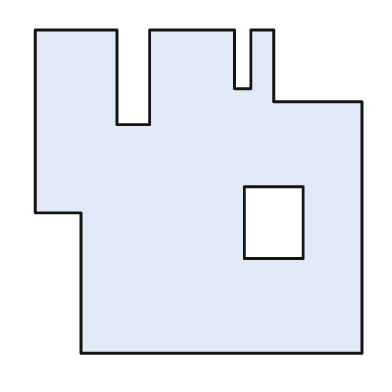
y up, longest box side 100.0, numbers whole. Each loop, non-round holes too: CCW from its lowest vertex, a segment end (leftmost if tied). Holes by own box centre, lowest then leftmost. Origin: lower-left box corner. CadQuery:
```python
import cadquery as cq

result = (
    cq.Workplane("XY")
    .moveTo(14.0, 0.0)
    .lineTo(100.0, 0.0)
    .lineTo(100.0, 77.0)
    .lineTo(73.0, 77.0)
    .lineTo(73.0, 99.0)
    .lineTo(66.0, 99.0)
    .lineTo(66.0, 81.0)
    .lineTo(61.0, 81.0)
    .lineTo(61.0, 99.0)
    .lineTo(35.0, 99.0)
    .lineTo(35.0, 70.0)
    .lineTo(25.0, 70.0)
    .lineTo(25.0, 99.0)
    .lineTo(0.0, 99.0)
    .lineTo(0.0, 43.0)
    .lineTo(14.0, 43.0)
    .close()
    .moveTo(64.0, 29.0)
    .lineTo(82.0, 29.0)
    .lineTo(82.0, 51.0)
    .lineTo(64.0, 51.0)
    .close()
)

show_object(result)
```